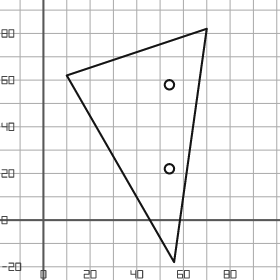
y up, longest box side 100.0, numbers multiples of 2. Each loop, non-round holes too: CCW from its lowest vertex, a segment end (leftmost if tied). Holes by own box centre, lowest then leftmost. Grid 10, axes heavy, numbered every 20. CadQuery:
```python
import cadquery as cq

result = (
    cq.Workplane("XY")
    .moveTo(56.0, -18.0)
    .lineTo(70.0, 82.0)
    .lineTo(10.0, 62.0)
    .close()
    .moveTo(54.0, 22.0)
    .circle(2.0)
    .moveTo(54.0, 58.0)
    .circle(2.0)
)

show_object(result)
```